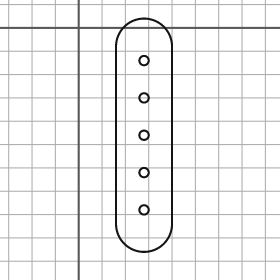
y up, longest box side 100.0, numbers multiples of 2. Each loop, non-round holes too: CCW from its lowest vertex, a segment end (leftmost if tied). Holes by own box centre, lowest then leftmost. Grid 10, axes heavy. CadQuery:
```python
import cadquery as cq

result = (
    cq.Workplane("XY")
    .moveTo(16.0, -84.0)
    .threePointArc((28.0, -96.0), (40.0, -84.0))
    .lineTo(40.0, -8.0)
    .threePointArc((28.0, 4.0), (16.0, -8.0))
    .close()
    .moveTo(28.0, -78.0)
    .circle(2.0)
    .moveTo(28.0, -62.0)
    .circle(2.0)
    .moveTo(28.0, -46.0)
    .circle(2.0)
    .moveTo(28.0, -30.0)
    .circle(2.0)
    .moveTo(28.0, -14.0)
    .circle(2.0)
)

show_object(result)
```